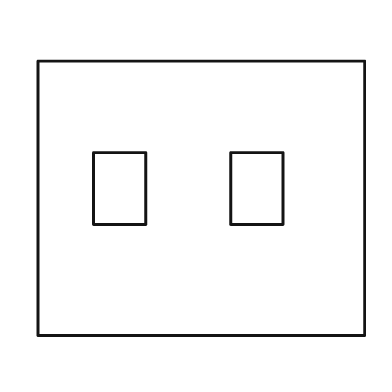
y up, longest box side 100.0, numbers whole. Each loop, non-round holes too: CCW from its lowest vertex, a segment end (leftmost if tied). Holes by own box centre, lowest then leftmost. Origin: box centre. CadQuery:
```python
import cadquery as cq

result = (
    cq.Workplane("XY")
    .moveTo(-50.0, -42.0)
    .lineTo(50.0, -42.0)
    .lineTo(50.0, 42.0)
    .lineTo(-50.0, 42.0)
    .close()
    .moveTo(-33.0, -8.0)
    .lineTo(-17.0, -8.0)
    .lineTo(-17.0, 14.0)
    .lineTo(-33.0, 14.0)
    .close()
    .moveTo(9.0, -8.0)
    .lineTo(25.0, -8.0)
    .lineTo(25.0, 14.0)
    .lineTo(9.0, 14.0)
    .close()
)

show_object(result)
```